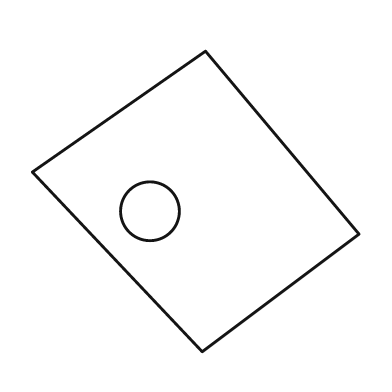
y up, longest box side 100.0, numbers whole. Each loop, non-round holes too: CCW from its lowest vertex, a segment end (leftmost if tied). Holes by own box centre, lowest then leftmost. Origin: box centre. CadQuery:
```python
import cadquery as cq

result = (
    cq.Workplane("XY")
    .moveTo(2.0, -46.0)
    .lineTo(50.0, -10.0)
    .lineTo(3.0, 46.0)
    .lineTo(-50.0, 9.0)
    .close()
    .moveTo(-14.0, -3.0)
    .circle(9.0)
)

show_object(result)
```